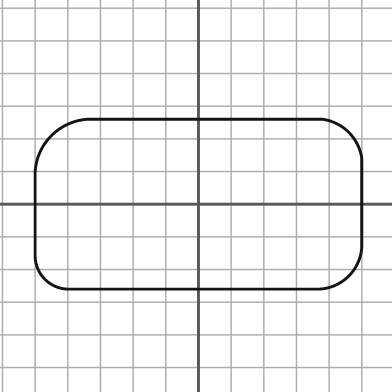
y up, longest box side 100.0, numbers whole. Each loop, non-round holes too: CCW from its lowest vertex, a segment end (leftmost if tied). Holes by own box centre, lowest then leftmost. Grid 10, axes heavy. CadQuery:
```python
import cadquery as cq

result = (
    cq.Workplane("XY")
    .moveTo(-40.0, -26.0)
    .lineTo(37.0, -26.0)
    .threePointArc((46.0, -22.0), (50.0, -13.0))
    .lineTo(50.0, 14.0)
    .threePointArc((46.0, 22.0), (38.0, 26.0))
    .lineTo(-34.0, 26.0)
    .threePointArc((-45.0, 21.0), (-50.0, 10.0))
    .lineTo(-50.0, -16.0)
    .threePointArc((-47.0, -23.0), (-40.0, -26.0))
    .close()
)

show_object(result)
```